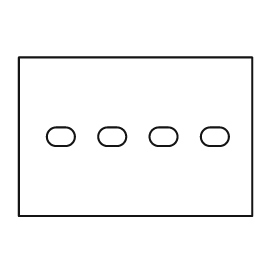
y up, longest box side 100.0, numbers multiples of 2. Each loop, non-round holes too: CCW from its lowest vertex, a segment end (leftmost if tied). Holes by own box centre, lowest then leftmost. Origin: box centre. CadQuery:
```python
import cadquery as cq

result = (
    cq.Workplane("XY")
    .moveTo(-50.0, -34.0)
    .lineTo(50.0, -34.0)
    .lineTo(50.0, 34.0)
    .lineTo(-50.0, 34.0)
    .close()
    .moveTo(-34.0, -4.0)
    .lineTo(-30.0, -4.0)
    .threePointArc((-26.0, 0.0), (-30.0, 4.0))
    .lineTo(-34.0, 4.0)
    .threePointArc((-38.0, 0.0), (-34.0, -4.0))
    .close()
    .moveTo(-12.0, -4.0)
    .lineTo(-8.0, -4.0)
    .threePointArc((-4.0, 0.0), (-8.0, 4.0))
    .lineTo(-12.0, 4.0)
    .threePointArc((-16.0, 0.0), (-12.0, -4.0))
    .close()
    .moveTo(10.0, -4.0)
    .lineTo(14.0, -4.0)
    .threePointArc((18.0, 0.0), (14.0, 4.0))
    .lineTo(10.0, 4.0)
    .threePointArc((6.0, 0.0), (10.0, -4.0))
    .close()
    .moveTo(32.0, -4.0)
    .lineTo(36.0, -4.0)
    .threePointArc((40.0, 0.0), (36.0, 4.0))
    .lineTo(32.0, 4.0)
    .threePointArc((28.0, 0.0), (32.0, -4.0))
    .close()
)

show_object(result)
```